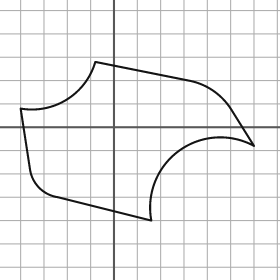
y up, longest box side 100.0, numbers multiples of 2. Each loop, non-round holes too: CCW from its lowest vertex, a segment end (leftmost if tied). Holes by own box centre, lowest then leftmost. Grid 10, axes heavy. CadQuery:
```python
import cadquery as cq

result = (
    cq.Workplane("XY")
    .moveTo(16.0, -40.0)
    .threePointArc((28.0, -10.0), (60.0, -8.0))
    .lineTo(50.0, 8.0)
    .threePointArc((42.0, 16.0), (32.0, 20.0))
    .lineTo(-8.0, 28.0)
    .threePointArc((-20.0, 12.0), (-40.0, 8.0))
    .lineTo(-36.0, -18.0)
    .threePointArc((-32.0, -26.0), (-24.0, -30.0))
    .close()
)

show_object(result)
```